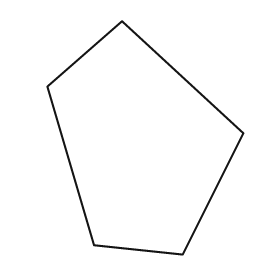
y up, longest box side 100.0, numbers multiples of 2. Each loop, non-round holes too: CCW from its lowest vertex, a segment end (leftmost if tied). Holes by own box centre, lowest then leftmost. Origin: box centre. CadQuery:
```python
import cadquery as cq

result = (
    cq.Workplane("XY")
    .moveTo(16.0, -50.0)
    .lineTo(42.0, 2.0)
    .lineTo(-10.0, 50.0)
    .lineTo(-42.0, 22.0)
    .lineTo(-22.0, -46.0)
    .close()
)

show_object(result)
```